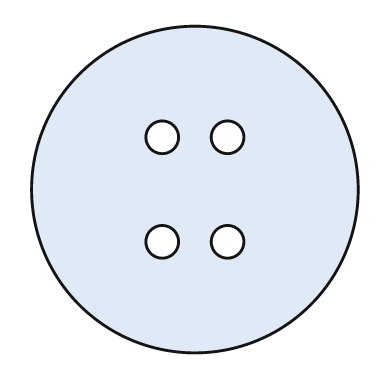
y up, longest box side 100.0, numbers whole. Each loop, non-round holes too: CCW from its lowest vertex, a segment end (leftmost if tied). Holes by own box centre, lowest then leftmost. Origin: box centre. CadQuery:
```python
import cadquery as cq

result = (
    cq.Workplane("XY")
    .moveTo(0.0, 0.0)
    .circle(50.0)
    .moveTo(-10.0, -16.0)
    .circle(5.0)
    .moveTo(10.0, -16.0)
    .circle(5.0)
    .moveTo(-10.0, 16.0)
    .circle(5.0)
    .moveTo(10.0, 16.0)
    .circle(5.0)
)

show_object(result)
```